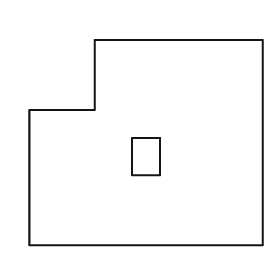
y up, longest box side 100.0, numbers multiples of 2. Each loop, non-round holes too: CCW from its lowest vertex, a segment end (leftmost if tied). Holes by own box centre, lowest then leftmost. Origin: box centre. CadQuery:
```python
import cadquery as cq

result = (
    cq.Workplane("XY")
    .moveTo(-50.0, -44.0)
    .lineTo(50.0, -44.0)
    .lineTo(50.0, 44.0)
    .lineTo(-22.0, 44.0)
    .lineTo(-22.0, 14.0)
    .lineTo(-50.0, 14.0)
    .close()
    .moveTo(-6.0, -14.0)
    .lineTo(6.0, -14.0)
    .lineTo(6.0, 2.0)
    .lineTo(-6.0, 2.0)
    .close()
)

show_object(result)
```